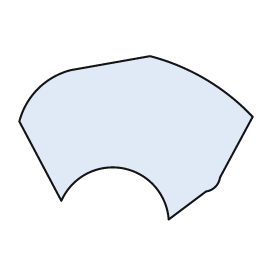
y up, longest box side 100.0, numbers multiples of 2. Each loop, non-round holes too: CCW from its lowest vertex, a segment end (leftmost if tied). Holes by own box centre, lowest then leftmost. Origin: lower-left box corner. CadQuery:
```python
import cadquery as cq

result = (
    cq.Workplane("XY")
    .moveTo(64.0, 0.0)
    .lineTo(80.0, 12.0)
    .threePointArc((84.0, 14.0), (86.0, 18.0))
    .lineTo(100.0, 44.0)
    .threePointArc((80.0, 60.0), (56.0, 70.0))
    .lineTo(22.0, 64.0)
    .threePointArc((8.0, 56.0), (0.0, 42.0))
    .lineTo(18.0, 8.0)
    .threePointArc((44.0, 22.0), (64.0, 0.0))
    .close()
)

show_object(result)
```